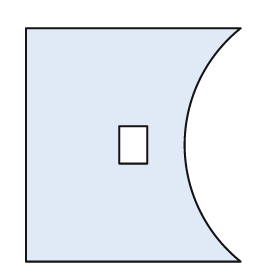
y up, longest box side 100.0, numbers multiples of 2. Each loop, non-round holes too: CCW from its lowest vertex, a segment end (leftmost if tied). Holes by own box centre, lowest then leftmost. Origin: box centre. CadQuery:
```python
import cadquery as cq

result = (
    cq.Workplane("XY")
    .moveTo(-46.0, -50.0)
    .lineTo(46.0, -50.0)
    .threePointArc((22.0, 0.0), (46.0, 50.0))
    .lineTo(-46.0, 50.0)
    .close()
    .moveTo(-6.0, -8.0)
    .lineTo(6.0, -8.0)
    .lineTo(6.0, 8.0)
    .lineTo(-6.0, 8.0)
    .close()
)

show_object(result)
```